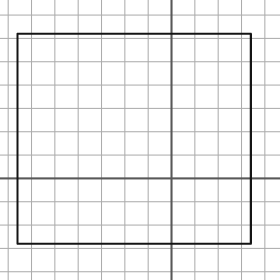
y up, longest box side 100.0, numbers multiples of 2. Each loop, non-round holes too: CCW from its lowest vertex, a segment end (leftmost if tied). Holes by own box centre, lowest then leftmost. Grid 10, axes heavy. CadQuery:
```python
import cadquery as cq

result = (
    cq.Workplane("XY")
    .moveTo(-66.0, -28.0)
    .lineTo(34.0, -28.0)
    .lineTo(34.0, 62.0)
    .lineTo(-66.0, 62.0)
    .close()
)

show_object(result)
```